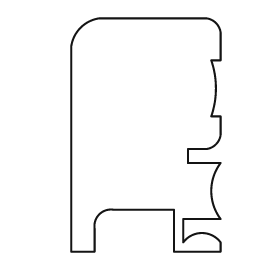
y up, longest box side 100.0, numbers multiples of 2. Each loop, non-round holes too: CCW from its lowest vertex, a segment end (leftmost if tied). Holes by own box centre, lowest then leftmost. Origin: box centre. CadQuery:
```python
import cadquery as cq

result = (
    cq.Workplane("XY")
    .moveTo(-32.0, -50.0)
    .lineTo(-22.0, -50.0)
    .lineTo(-22.0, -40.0)
    .threePointArc((-20.0, -34.0), (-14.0, -32.0))
    .lineTo(12.0, -32.0)
    .lineTo(12.0, -50.0)
    .lineTo(32.0, -50.0)
    .lineTo(32.0, -46.0)
    .threePointArc((24.0, -42.0), (16.0, -46.0))
    .lineTo(16.0, -36.0)
    .lineTo(32.0, -36.0)
    .threePointArc((28.0, -24.0), (32.0, -12.0))
    .lineTo(18.0, -12.0)
    .lineTo(18.0, -6.0)
    .lineTo(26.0, -6.0)
    .threePointArc((30.0, -4.0), (32.0, 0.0))
    .lineTo(32.0, 8.0)
    .lineTo(28.0, 8.0)
    .threePointArc((30.0, 20.0), (28.0, 32.0))
    .lineTo(32.0, 32.0)
    .lineTo(32.0, 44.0)
    .threePointArc((30.0, 48.0), (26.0, 50.0))
    .lineTo(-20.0, 50.0)
    .threePointArc((-28.0, 46.0), (-32.0, 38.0))
    .close()
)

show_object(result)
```